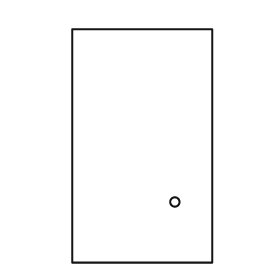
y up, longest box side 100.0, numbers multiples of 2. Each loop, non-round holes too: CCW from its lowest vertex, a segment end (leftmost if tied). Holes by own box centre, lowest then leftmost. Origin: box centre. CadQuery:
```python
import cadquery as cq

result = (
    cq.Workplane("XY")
    .moveTo(-30.0, -50.0)
    .lineTo(30.0, -50.0)
    .lineTo(30.0, 50.0)
    .lineTo(-30.0, 50.0)
    .close()
    .moveTo(14.0, -24.0)
    .circle(2.0)
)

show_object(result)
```